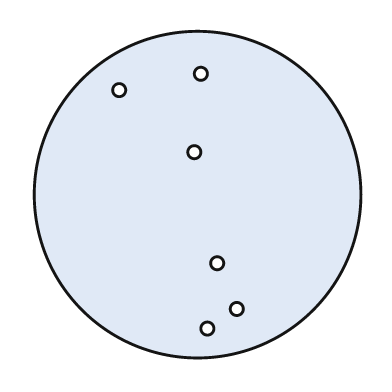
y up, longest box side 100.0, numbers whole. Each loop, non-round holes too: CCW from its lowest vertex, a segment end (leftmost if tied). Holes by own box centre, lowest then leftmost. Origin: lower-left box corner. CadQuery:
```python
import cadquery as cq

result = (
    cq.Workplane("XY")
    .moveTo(50.0, 50.0)
    .circle(50.0)
    .moveTo(53.0, 9.0)
    .circle(2.0)
    .moveTo(62.0, 15.0)
    .circle(2.0)
    .moveTo(56.0, 29.0)
    .circle(2.0)
    .moveTo(49.0, 63.0)
    .circle(2.0)
    .moveTo(26.0, 82.0)
    .circle(2.0)
    .moveTo(51.0, 87.0)
    .circle(2.0)
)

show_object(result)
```